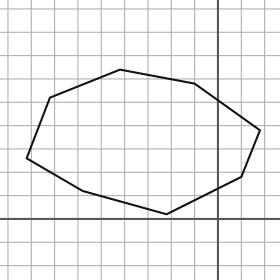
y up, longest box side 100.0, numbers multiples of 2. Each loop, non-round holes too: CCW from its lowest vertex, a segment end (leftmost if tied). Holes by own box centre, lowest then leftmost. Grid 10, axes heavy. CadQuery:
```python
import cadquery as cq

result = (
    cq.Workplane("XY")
    .moveTo(-22.0, 2.0)
    .lineTo(10.0, 18.0)
    .lineTo(18.0, 38.0)
    .lineTo(-10.0, 58.0)
    .lineTo(-42.0, 64.0)
    .lineTo(-72.0, 52.0)
    .lineTo(-82.0, 26.0)
    .lineTo(-58.0, 12.0)
    .close()
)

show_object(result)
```